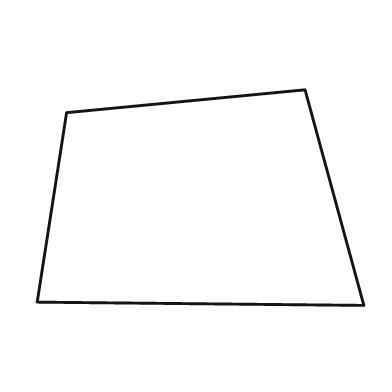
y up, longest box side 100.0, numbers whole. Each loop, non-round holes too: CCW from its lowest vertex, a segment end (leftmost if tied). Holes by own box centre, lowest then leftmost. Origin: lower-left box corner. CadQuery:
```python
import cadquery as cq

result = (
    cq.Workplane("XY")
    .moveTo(100.0, 0.0)
    .lineTo(82.0, 66.0)
    .lineTo(9.0, 59.0)
    .lineTo(0.0, 1.0)
    .close()
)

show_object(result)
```